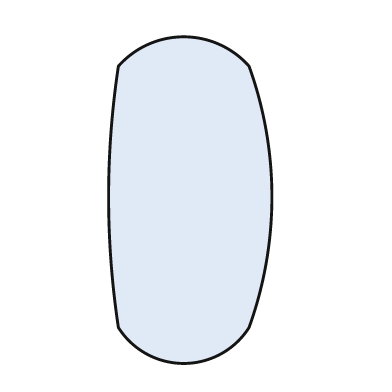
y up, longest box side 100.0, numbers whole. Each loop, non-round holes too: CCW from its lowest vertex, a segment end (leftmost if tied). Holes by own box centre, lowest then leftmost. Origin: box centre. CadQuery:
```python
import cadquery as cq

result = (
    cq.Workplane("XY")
    .moveTo(-22.0, -39.0)
    .threePointArc((-2.0, -50.0), (18.0, -39.0))
    .threePointArc((25.0, 1.0), (18.0, 41.0))
    .threePointArc((-2.0, 50.0), (-22.0, 41.0))
    .threePointArc((-25.0, 1.0), (-22.0, -39.0))
    .close()
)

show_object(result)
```